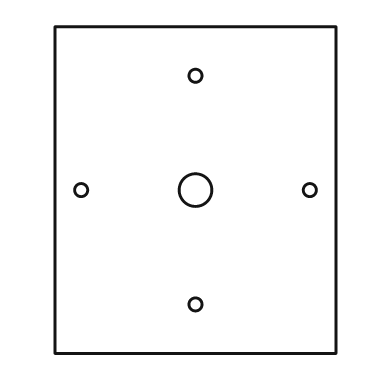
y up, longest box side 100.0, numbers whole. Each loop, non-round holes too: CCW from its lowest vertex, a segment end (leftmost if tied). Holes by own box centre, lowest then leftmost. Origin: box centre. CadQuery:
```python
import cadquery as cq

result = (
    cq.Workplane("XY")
    .moveTo(-43.0, -50.0)
    .lineTo(43.0, -50.0)
    .lineTo(43.0, 50.0)
    .lineTo(-43.0, 50.0)
    .close()
    .moveTo(0.0, -35.0)
    .circle(2.0)
    .moveTo(-35.0, 0.0)
    .circle(2.0)
    .moveTo(0.0, 0.0)
    .circle(5.0)
    .moveTo(35.0, 0.0)
    .circle(2.0)
    .moveTo(0.0, 35.0)
    .circle(2.0)
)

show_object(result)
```